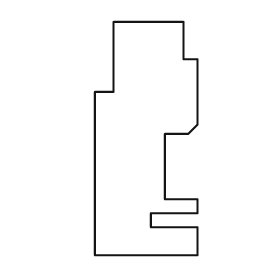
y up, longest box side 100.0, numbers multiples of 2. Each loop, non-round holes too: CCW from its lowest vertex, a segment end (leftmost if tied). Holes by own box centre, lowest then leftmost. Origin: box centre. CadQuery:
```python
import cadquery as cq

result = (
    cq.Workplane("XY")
    .moveTo(-22.0, -50.0)
    .lineTo(22.0, -50.0)
    .lineTo(22.0, -38.0)
    .lineTo(2.0, -38.0)
    .lineTo(2.0, -32.0)
    .lineTo(22.0, -32.0)
    .lineTo(22.0, -26.0)
    .lineTo(8.0, -26.0)
    .lineTo(8.0, 2.0)
    .lineTo(18.0, 2.0)
    .lineTo(22.0, 6.0)
    .lineTo(22.0, 34.0)
    .lineTo(16.0, 34.0)
    .lineTo(16.0, 50.0)
    .lineTo(-14.0, 50.0)
    .lineTo(-14.0, 20.0)
    .lineTo(-22.0, 20.0)
    .close()
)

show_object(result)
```